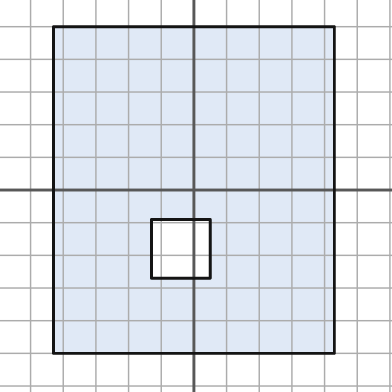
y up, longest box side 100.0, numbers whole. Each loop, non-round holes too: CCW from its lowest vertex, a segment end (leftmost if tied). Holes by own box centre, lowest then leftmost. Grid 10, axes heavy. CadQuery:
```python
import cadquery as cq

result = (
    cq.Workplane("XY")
    .moveTo(-43.0, -50.0)
    .lineTo(43.0, -50.0)
    .lineTo(43.0, 50.0)
    .lineTo(-43.0, 50.0)
    .close()
    .moveTo(-13.0, -27.0)
    .lineTo(5.0, -27.0)
    .lineTo(5.0, -9.0)
    .lineTo(-13.0, -9.0)
    .close()
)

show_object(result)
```